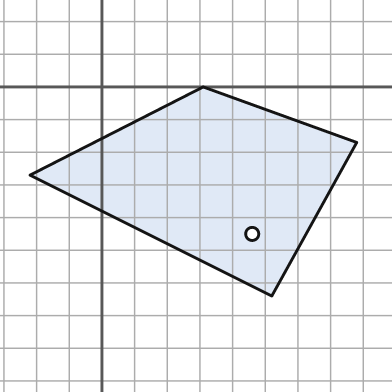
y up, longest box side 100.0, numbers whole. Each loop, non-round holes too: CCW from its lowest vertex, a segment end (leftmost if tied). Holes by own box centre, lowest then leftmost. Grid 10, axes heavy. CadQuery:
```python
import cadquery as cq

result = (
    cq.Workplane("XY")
    .moveTo(52.0, -64.0)
    .lineTo(78.0, -17.0)
    .lineTo(31.0, 0.0)
    .lineTo(-22.0, -27.0)
    .close()
    .moveTo(46.0, -45.0)
    .circle(2.0)
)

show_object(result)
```